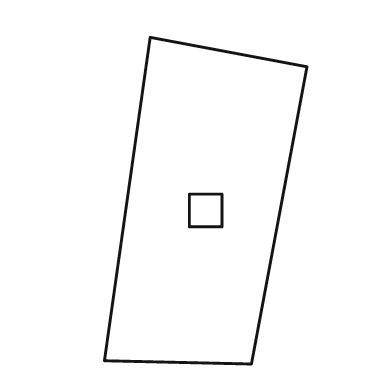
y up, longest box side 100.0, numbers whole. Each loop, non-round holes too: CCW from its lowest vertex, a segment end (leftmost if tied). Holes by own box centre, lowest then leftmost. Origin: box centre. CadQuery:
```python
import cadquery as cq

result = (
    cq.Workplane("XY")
    .moveTo(14.0, -50.0)
    .lineTo(31.0, 41.0)
    .lineTo(-17.0, 50.0)
    .lineTo(-31.0, -49.0)
    .close()
    .moveTo(-5.0, -8.0)
    .lineTo(5.0, -8.0)
    .lineTo(5.0, 2.0)
    .lineTo(-5.0, 2.0)
    .close()
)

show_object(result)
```